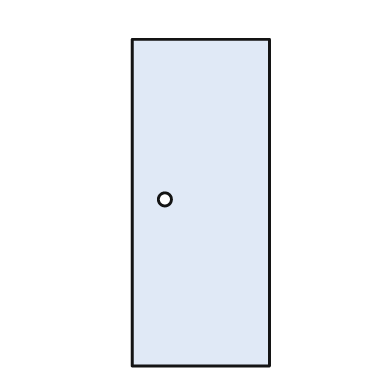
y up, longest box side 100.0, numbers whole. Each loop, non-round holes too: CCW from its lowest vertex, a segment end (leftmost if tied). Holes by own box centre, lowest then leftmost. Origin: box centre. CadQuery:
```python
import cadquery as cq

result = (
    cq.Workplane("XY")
    .moveTo(-21.0, -50.0)
    .lineTo(21.0, -50.0)
    .lineTo(21.0, 50.0)
    .lineTo(-21.0, 50.0)
    .close()
    .moveTo(-11.0, 1.0)
    .circle(2.0)
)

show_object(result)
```